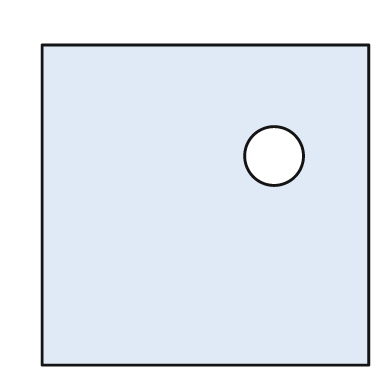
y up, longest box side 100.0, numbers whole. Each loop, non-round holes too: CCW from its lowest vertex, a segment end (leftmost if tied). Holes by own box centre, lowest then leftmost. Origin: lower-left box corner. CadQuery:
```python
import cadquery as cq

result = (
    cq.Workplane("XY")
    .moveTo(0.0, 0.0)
    .lineTo(100.0, 0.0)
    .lineTo(100.0, 98.0)
    .lineTo(0.0, 98.0)
    .close()
    .moveTo(71.0, 64.0)
    .circle(9.0)
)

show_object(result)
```